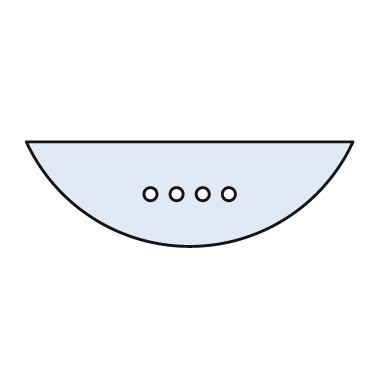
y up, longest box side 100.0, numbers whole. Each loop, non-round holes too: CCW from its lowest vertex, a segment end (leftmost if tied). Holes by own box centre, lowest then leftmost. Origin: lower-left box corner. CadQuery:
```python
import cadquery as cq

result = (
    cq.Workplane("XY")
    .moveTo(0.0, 32.0)
    .threePointArc((50.0, 0.0), (100.0, 32.0))
    .close()
    .moveTo(38.0, 16.0)
    .circle(2.0)
    .moveTo(46.0, 16.0)
    .circle(2.0)
    .moveTo(54.0, 16.0)
    .circle(2.0)
    .moveTo(62.0, 16.0)
    .circle(2.0)
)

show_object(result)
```